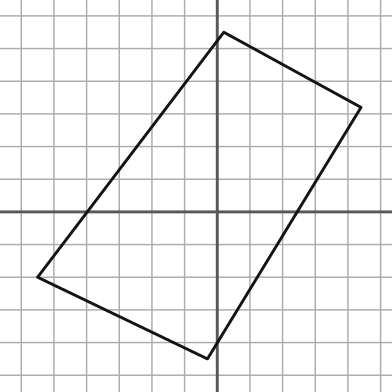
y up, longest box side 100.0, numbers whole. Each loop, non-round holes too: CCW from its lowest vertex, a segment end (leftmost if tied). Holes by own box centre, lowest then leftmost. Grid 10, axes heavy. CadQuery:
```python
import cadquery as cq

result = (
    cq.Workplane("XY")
    .moveTo(-3.0, -45.0)
    .lineTo(44.0, 32.0)
    .lineTo(2.0, 55.0)
    .lineTo(-55.0, -20.0)
    .close()
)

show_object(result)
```